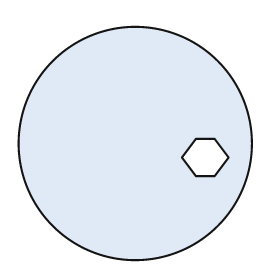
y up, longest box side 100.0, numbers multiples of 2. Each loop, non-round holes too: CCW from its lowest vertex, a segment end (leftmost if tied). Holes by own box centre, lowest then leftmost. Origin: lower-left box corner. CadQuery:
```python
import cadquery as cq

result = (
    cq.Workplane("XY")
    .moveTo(50.0, 50.0)
    .circle(50.0)
    .moveTo(76.0, 36.0)
    .lineTo(84.0, 36.0)
    .lineTo(90.0, 44.0)
    .lineTo(84.0, 52.0)
    .lineTo(76.0, 52.0)
    .lineTo(70.0, 44.0)
    .close()
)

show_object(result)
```